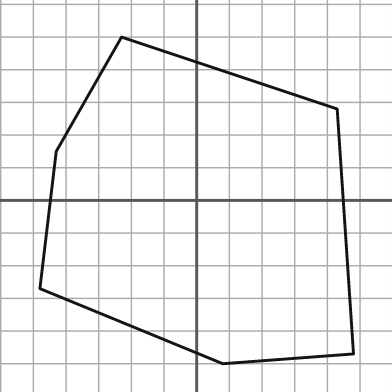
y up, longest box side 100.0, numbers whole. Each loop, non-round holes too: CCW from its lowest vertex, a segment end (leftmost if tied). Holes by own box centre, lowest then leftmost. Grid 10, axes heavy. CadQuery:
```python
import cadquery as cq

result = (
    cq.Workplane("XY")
    .moveTo(8.0, -50.0)
    .lineTo(48.0, -47.0)
    .lineTo(43.0, 28.0)
    .lineTo(-23.0, 50.0)
    .lineTo(-43.0, 15.0)
    .lineTo(-48.0, -27.0)
    .close()
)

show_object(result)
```